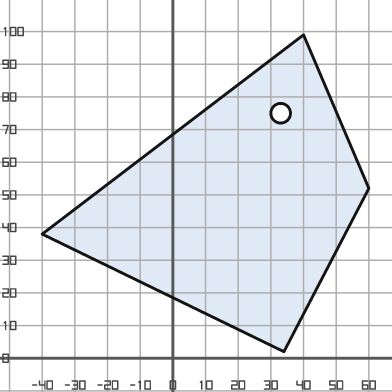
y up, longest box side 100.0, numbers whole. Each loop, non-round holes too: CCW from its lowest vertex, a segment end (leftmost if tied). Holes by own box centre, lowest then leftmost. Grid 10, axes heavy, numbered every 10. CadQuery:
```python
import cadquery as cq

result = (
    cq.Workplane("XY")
    .moveTo(34.0, 2.0)
    .lineTo(60.0, 52.0)
    .lineTo(40.0, 99.0)
    .lineTo(-40.0, 38.0)
    .close()
    .moveTo(33.0, 75.0)
    .circle(3.0)
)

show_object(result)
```